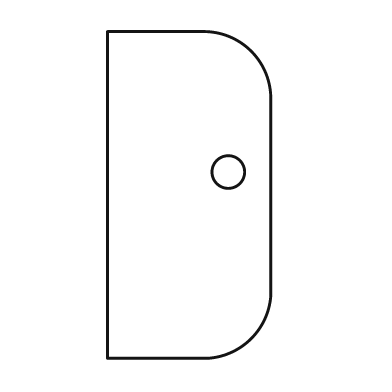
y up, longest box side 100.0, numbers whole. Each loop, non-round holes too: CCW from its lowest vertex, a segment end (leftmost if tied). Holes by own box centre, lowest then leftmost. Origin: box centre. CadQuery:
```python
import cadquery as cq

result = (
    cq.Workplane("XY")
    .moveTo(-25.0, -50.0)
    .lineTo(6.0, -50.0)
    .threePointArc((19.0, -44.0), (25.0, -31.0))
    .lineTo(25.0, 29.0)
    .threePointArc((19.0, 44.0), (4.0, 50.0))
    .lineTo(-25.0, 50.0)
    .close()
    .moveTo(12.0, 7.0)
    .circle(5.0)
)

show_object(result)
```